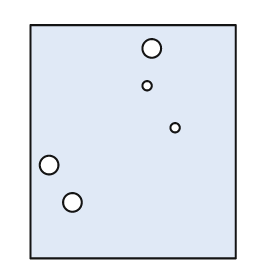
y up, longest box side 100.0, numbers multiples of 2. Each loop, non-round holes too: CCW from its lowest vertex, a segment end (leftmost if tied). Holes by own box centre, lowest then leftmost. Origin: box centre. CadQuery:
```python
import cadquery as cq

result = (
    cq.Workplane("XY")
    .moveTo(-44.0, -50.0)
    .lineTo(44.0, -50.0)
    .lineTo(44.0, 50.0)
    .lineTo(-44.0, 50.0)
    .close()
    .moveTo(-26.0, -26.0)
    .circle(4.0)
    .moveTo(-36.0, -10.0)
    .circle(4.0)
    .moveTo(18.0, 6.0)
    .circle(2.0)
    .moveTo(6.0, 24.0)
    .circle(2.0)
    .moveTo(8.0, 40.0)
    .circle(4.0)
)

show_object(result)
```